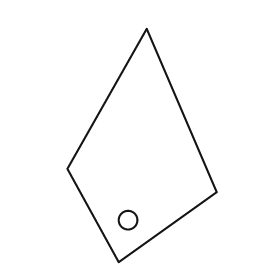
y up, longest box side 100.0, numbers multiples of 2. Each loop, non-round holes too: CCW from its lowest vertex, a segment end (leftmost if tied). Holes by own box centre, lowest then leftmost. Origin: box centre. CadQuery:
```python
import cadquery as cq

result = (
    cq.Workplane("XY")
    .moveTo(-10.0, -50.0)
    .lineTo(32.0, -20.0)
    .lineTo(2.0, 50.0)
    .lineTo(-32.0, -10.0)
    .close()
    .moveTo(-6.0, -32.0)
    .circle(4.0)
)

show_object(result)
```